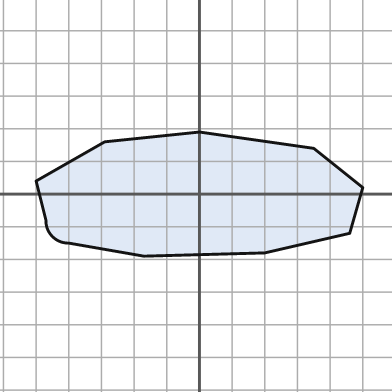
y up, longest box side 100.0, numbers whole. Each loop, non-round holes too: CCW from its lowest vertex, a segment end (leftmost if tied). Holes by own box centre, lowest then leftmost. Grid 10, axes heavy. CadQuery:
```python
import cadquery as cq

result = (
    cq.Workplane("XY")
    .moveTo(-17.0, -19.0)
    .lineTo(20.0, -18.0)
    .lineTo(46.0, -12.0)
    .lineTo(50.0, 2.0)
    .lineTo(35.0, 14.0)
    .lineTo(0.0, 19.0)
    .lineTo(-29.0, 16.0)
    .lineTo(-50.0, 4.0)
    .lineTo(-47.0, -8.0)
    .threePointArc((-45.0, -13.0), (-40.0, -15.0))
    .close()
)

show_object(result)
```